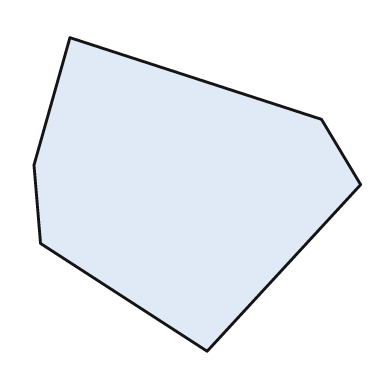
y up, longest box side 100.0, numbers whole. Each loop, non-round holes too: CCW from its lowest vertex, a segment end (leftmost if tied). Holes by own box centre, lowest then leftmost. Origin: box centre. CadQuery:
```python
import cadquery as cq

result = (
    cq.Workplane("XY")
    .moveTo(3.0, -48.0)
    .lineTo(50.0, 3.0)
    .lineTo(38.0, 23.0)
    .lineTo(-39.0, 48.0)
    .lineTo(-50.0, 9.0)
    .lineTo(-48.0, -15.0)
    .close()
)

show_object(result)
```